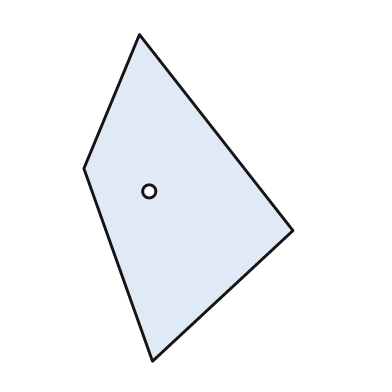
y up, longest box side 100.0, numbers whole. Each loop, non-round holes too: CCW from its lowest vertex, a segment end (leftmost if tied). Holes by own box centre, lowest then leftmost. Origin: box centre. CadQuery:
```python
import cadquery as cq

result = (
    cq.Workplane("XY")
    .moveTo(-11.0, -50.0)
    .lineTo(32.0, -10.0)
    .lineTo(-15.0, 50.0)
    .lineTo(-32.0, 9.0)
    .close()
    .moveTo(-12.0, 2.0)
    .circle(2.0)
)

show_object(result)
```